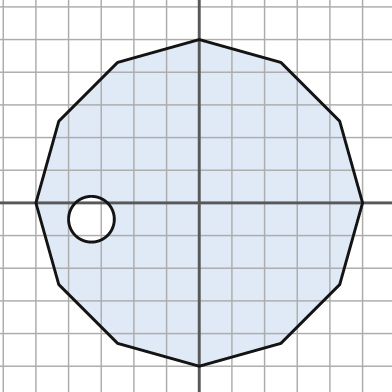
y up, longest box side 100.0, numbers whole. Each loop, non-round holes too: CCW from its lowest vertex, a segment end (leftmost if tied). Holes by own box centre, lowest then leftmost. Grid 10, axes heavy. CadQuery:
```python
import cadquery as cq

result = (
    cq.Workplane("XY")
    .moveTo(0.0, -50.0)
    .lineTo(25.0, -43.0)
    .lineTo(43.0, -25.0)
    .lineTo(50.0, 0.0)
    .lineTo(43.0, 25.0)
    .lineTo(25.0, 43.0)
    .lineTo(0.0, 50.0)
    .lineTo(-25.0, 43.0)
    .lineTo(-43.0, 25.0)
    .lineTo(-50.0, 0.0)
    .lineTo(-43.0, -25.0)
    .lineTo(-25.0, -43.0)
    .close()
    .moveTo(-33.0, -5.0)
    .circle(7.0)
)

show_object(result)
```